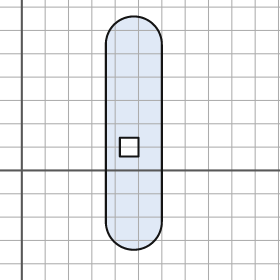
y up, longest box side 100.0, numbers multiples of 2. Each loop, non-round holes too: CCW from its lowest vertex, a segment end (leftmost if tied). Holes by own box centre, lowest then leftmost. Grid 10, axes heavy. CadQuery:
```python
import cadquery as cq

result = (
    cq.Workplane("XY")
    .moveTo(36.0, -22.0)
    .threePointArc((48.0, -34.0), (60.0, -22.0))
    .lineTo(60.0, 54.0)
    .threePointArc((48.0, 66.0), (36.0, 54.0))
    .close()
    .moveTo(42.0, 6.0)
    .lineTo(50.0, 6.0)
    .lineTo(50.0, 14.0)
    .lineTo(42.0, 14.0)
    .close()
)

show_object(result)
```